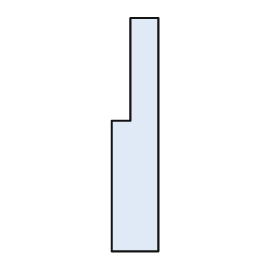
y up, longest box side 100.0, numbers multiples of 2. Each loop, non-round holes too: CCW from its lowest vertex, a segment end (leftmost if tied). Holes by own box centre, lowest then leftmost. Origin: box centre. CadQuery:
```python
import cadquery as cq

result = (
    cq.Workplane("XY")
    .moveTo(-10.0, -50.0)
    .lineTo(10.0, -50.0)
    .lineTo(10.0, 50.0)
    .lineTo(-2.0, 50.0)
    .lineTo(-2.0, 6.0)
    .lineTo(-10.0, 6.0)
    .close()
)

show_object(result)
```